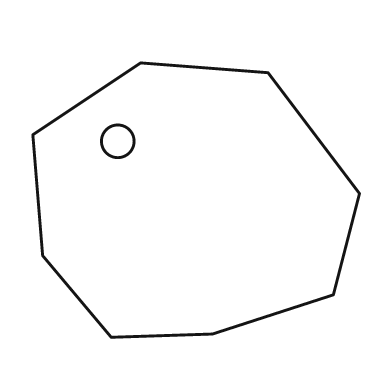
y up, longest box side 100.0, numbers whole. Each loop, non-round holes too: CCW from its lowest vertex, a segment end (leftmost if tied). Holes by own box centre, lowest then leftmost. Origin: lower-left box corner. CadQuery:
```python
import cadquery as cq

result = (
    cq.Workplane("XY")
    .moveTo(24.0, 0.0)
    .lineTo(55.0, 1.0)
    .lineTo(92.0, 13.0)
    .lineTo(100.0, 44.0)
    .lineTo(72.0, 81.0)
    .lineTo(33.0, 84.0)
    .lineTo(0.0, 62.0)
    .lineTo(3.0, 25.0)
    .close()
    .moveTo(26.0, 60.0)
    .circle(5.0)
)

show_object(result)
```